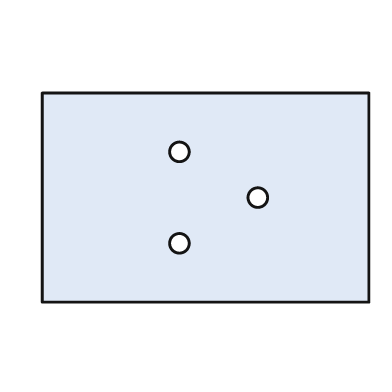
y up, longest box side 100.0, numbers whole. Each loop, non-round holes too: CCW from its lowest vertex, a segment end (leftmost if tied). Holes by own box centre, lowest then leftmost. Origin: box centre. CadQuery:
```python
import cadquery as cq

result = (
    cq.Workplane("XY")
    .moveTo(-50.0, -32.0)
    .lineTo(50.0, -32.0)
    .lineTo(50.0, 32.0)
    .lineTo(-50.0, 32.0)
    .close()
    .moveTo(-8.0, -14.0)
    .circle(3.0)
    .moveTo(16.0, 0.0)
    .circle(3.0)
    .moveTo(-8.0, 14.0)
    .circle(3.0)
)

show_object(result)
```